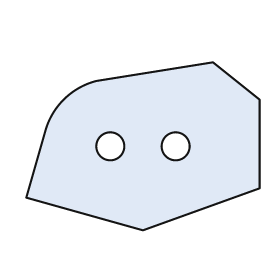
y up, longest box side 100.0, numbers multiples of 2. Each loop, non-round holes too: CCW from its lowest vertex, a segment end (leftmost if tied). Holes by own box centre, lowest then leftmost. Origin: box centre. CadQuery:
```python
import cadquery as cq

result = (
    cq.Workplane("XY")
    .moveTo(0.0, -36.0)
    .lineTo(50.0, -18.0)
    .lineTo(50.0, 20.0)
    .lineTo(30.0, 36.0)
    .lineTo(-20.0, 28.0)
    .threePointArc((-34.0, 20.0), (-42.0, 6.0))
    .lineTo(-50.0, -22.0)
    .close()
    .moveTo(-14.0, 0.0)
    .circle(6.0)
    .moveTo(14.0, 0.0)
    .circle(6.0)
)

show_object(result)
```